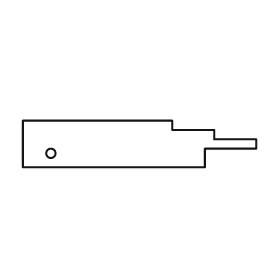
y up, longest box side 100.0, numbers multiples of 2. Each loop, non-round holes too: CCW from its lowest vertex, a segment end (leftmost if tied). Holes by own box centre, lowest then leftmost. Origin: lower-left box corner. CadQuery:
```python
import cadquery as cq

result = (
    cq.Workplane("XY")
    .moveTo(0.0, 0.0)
    .lineTo(78.0, 0.0)
    .lineTo(78.0, 8.0)
    .lineTo(100.0, 8.0)
    .lineTo(100.0, 12.0)
    .lineTo(82.0, 12.0)
    .lineTo(82.0, 16.0)
    .lineTo(64.0, 16.0)
    .lineTo(64.0, 20.0)
    .lineTo(0.0, 20.0)
    .close()
    .moveTo(12.0, 6.0)
    .circle(2.0)
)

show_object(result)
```